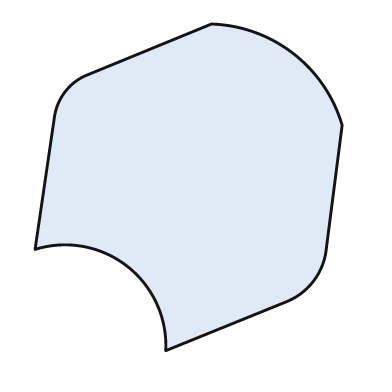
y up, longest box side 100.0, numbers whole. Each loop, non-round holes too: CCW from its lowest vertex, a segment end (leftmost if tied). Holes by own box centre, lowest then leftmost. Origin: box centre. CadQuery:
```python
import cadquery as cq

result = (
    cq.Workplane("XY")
    .moveTo(-7.0, -50.0)
    .lineTo(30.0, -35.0)
    .threePointArc((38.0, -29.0), (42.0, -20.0))
    .lineTo(47.0, 19.0)
    .threePointArc((32.0, 41.0), (7.0, 50.0))
    .lineTo(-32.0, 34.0)
    .threePointArc((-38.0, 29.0), (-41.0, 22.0))
    .lineTo(-47.0, -19.0)
    .threePointArc((-19.0, -24.0), (-7.0, -50.0))
    .close()
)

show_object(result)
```